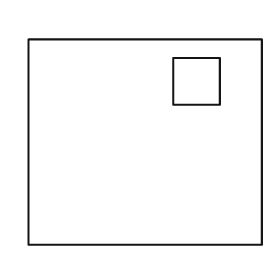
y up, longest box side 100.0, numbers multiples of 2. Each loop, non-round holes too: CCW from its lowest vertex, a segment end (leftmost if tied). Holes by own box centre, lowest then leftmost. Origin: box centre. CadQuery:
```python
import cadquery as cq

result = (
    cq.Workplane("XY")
    .moveTo(-50.0, -44.0)
    .lineTo(50.0, -44.0)
    .lineTo(50.0, 44.0)
    .lineTo(-50.0, 44.0)
    .close()
    .moveTo(12.0, 16.0)
    .lineTo(32.0, 16.0)
    .lineTo(32.0, 36.0)
    .lineTo(12.0, 36.0)
    .close()
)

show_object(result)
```